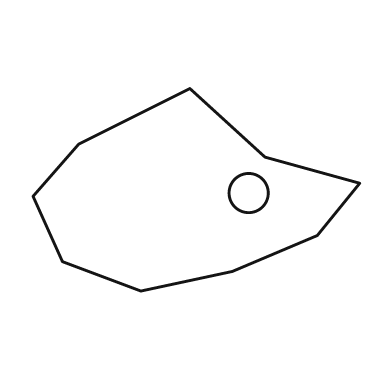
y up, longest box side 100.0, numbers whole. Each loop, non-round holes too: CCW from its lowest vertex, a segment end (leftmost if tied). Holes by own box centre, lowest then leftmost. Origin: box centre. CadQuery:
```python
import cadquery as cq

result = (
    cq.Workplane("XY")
    .moveTo(-17.0, -31.0)
    .lineTo(11.0, -25.0)
    .lineTo(37.0, -14.0)
    .lineTo(50.0, 2.0)
    .lineTo(21.0, 10.0)
    .lineTo(-2.0, 31.0)
    .lineTo(-36.0, 14.0)
    .lineTo(-50.0, -2.0)
    .lineTo(-41.0, -22.0)
    .close()
    .moveTo(16.0, -1.0)
    .circle(6.0)
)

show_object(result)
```